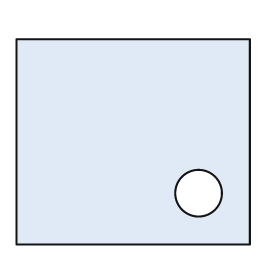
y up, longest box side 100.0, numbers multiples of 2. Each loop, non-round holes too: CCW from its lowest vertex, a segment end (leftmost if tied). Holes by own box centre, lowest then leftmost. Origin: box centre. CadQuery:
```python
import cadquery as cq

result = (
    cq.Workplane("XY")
    .moveTo(-50.0, -44.0)
    .lineTo(50.0, -44.0)
    .lineTo(50.0, 44.0)
    .lineTo(-50.0, 44.0)
    .close()
    .moveTo(28.0, -22.0)
    .circle(10.0)
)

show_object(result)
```